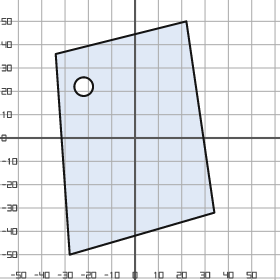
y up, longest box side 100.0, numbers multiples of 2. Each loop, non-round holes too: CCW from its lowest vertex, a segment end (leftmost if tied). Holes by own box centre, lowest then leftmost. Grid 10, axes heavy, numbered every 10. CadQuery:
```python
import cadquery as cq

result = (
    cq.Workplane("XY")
    .moveTo(-28.0, -50.0)
    .lineTo(34.0, -32.0)
    .lineTo(22.0, 50.0)
    .lineTo(-34.0, 36.0)
    .close()
    .moveTo(-22.0, 22.0)
    .circle(4.0)
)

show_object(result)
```